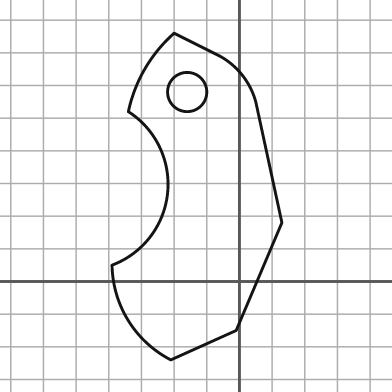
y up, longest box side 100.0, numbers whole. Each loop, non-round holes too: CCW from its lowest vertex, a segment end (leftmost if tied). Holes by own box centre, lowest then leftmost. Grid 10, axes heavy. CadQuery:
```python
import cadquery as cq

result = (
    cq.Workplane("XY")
    .moveTo(-21.0, -24.0)
    .lineTo(-1.0, -15.0)
    .lineTo(13.0, 18.0)
    .lineTo(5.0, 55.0)
    .threePointArc((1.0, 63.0), (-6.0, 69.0))
    .lineTo(-20.0, 76.0)
    .threePointArc((-29.0, 65.0), (-34.0, 52.0))
    .threePointArc((-22.0, 27.0), (-39.0, 5.0))
    .threePointArc((-34.0, -12.0), (-21.0, -24.0))
    .close()
    .moveTo(-16.0, 58.0)
    .circle(6.0)
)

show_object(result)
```